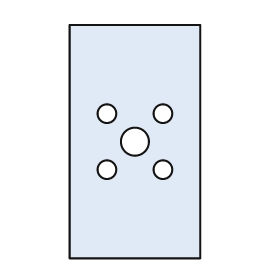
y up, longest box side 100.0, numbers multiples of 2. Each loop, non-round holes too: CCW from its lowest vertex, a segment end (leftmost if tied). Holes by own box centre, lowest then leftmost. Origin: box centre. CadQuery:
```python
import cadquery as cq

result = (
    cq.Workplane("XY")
    .moveTo(-28.0, -50.0)
    .lineTo(28.0, -50.0)
    .lineTo(28.0, 50.0)
    .lineTo(-28.0, 50.0)
    .close()
    .moveTo(-12.0, -12.0)
    .circle(4.0)
    .moveTo(12.0, -12.0)
    .circle(4.0)
    .moveTo(0.0, 0.0)
    .circle(6.0)
    .moveTo(-12.0, 12.0)
    .circle(4.0)
    .moveTo(12.0, 12.0)
    .circle(4.0)
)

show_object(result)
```